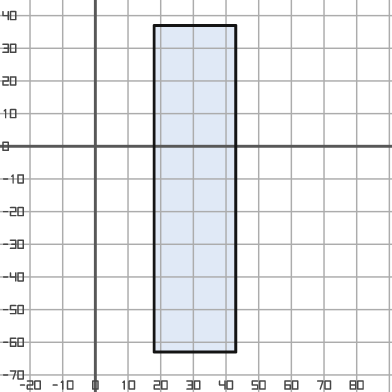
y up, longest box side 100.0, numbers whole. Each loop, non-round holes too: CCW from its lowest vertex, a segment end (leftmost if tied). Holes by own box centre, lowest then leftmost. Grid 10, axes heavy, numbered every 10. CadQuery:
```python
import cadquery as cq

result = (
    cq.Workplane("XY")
    .moveTo(18.0, -63.0)
    .lineTo(43.0, -63.0)
    .lineTo(43.0, 37.0)
    .lineTo(18.0, 37.0)
    .close()
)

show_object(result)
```